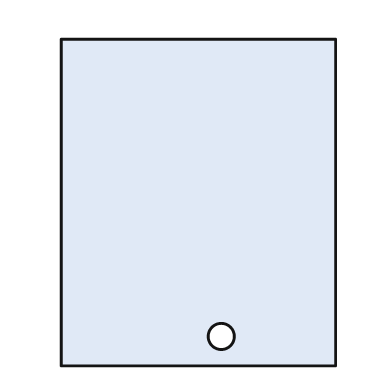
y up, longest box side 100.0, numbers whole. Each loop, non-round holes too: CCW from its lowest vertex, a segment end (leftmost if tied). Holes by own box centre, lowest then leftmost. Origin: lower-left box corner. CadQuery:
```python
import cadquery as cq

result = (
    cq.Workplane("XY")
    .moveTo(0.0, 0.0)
    .lineTo(84.0, 0.0)
    .lineTo(84.0, 100.0)
    .lineTo(0.0, 100.0)
    .close()
    .moveTo(49.0, 9.0)
    .circle(4.0)
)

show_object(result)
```